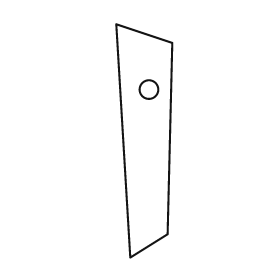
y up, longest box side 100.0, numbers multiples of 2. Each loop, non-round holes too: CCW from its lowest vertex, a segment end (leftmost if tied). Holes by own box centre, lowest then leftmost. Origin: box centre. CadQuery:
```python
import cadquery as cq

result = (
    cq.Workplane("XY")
    .moveTo(-6.0, -50.0)
    .lineTo(10.0, -40.0)
    .lineTo(12.0, 42.0)
    .lineTo(-12.0, 50.0)
    .close()
    .moveTo(2.0, 22.0)
    .circle(4.0)
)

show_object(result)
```